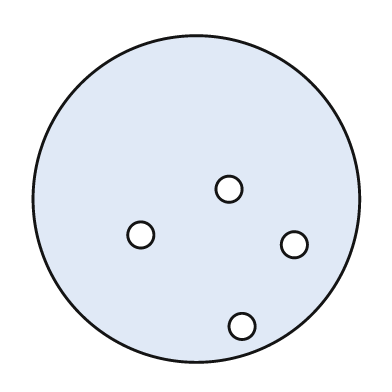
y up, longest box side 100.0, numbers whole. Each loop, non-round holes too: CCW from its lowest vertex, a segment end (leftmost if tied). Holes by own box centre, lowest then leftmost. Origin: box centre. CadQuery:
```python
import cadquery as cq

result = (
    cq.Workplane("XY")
    .moveTo(0.0, 0.0)
    .circle(50.0)
    .moveTo(14.0, -39.0)
    .circle(4.0)
    .moveTo(30.0, -14.0)
    .circle(4.0)
    .moveTo(-17.0, -11.0)
    .circle(4.0)
    .moveTo(10.0, 3.0)
    .circle(4.0)
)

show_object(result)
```